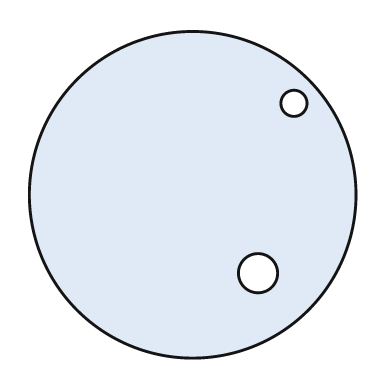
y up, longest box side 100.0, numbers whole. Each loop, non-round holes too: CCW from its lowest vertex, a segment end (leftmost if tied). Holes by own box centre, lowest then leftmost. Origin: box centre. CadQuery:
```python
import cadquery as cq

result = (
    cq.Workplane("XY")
    .moveTo(0.0, 0.0)
    .circle(50.0)
    .moveTo(20.0, -24.0)
    .circle(6.0)
    .moveTo(31.0, 28.0)
    .circle(4.0)
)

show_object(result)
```